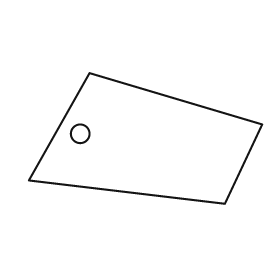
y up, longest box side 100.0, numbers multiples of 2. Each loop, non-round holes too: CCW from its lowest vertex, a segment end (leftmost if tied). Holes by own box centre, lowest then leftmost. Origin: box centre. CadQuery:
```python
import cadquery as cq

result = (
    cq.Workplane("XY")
    .moveTo(34.0, -28.0)
    .lineTo(50.0, 6.0)
    .lineTo(-24.0, 28.0)
    .lineTo(-50.0, -18.0)
    .close()
    .moveTo(-28.0, 2.0)
    .circle(4.0)
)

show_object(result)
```